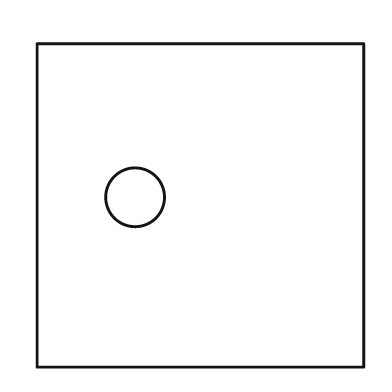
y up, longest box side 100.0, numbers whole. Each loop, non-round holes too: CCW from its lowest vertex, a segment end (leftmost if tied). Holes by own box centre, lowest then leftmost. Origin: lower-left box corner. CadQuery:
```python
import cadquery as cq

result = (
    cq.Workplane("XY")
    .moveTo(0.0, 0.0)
    .lineTo(100.0, 0.0)
    .lineTo(100.0, 99.0)
    .lineTo(0.0, 99.0)
    .close()
    .moveTo(30.0, 52.0)
    .circle(9.0)
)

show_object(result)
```